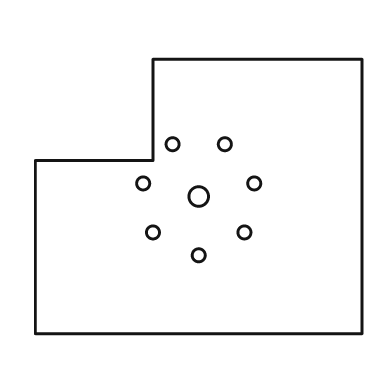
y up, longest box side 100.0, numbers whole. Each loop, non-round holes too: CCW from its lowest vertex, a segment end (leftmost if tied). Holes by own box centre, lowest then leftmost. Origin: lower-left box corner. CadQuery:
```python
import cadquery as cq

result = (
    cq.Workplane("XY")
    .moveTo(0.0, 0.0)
    .lineTo(100.0, 0.0)
    .lineTo(100.0, 84.0)
    .lineTo(36.0, 84.0)
    .lineTo(36.0, 53.0)
    .lineTo(0.0, 53.0)
    .close()
    .moveTo(50.0, 24.0)
    .circle(2.0)
    .moveTo(36.0, 31.0)
    .circle(2.0)
    .moveTo(64.0, 31.0)
    .circle(2.0)
    .moveTo(50.0, 42.0)
    .circle(3.0)
    .moveTo(33.0, 46.0)
    .circle(2.0)
    .moveTo(67.0, 46.0)
    .circle(2.0)
    .moveTo(42.0, 58.0)
    .circle(2.0)
    .moveTo(58.0, 58.0)
    .circle(2.0)
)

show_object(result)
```